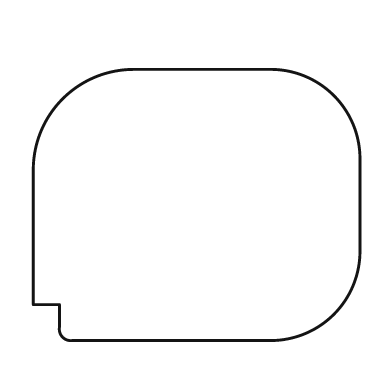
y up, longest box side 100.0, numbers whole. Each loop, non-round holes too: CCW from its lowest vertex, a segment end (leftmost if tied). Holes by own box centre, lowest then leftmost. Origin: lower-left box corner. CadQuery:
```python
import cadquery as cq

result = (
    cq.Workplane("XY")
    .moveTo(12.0, 0.0)
    .lineTo(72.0, 0.0)
    .threePointArc((92.0, 8.0), (100.0, 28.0))
    .lineTo(100.0, 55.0)
    .threePointArc((92.0, 75.0), (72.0, 83.0))
    .lineTo(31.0, 83.0)
    .threePointArc((9.0, 74.0), (0.0, 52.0))
    .lineTo(0.0, 11.0)
    .lineTo(8.0, 11.0)
    .lineTo(8.0, 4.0)
    .threePointArc((9.0, 1.0), (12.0, 0.0))
    .close()
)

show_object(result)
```